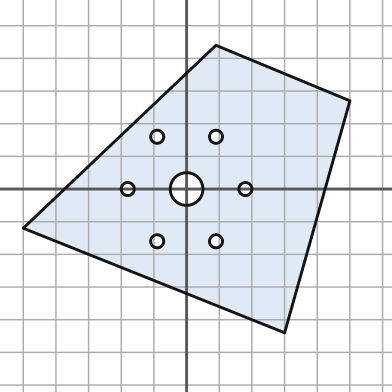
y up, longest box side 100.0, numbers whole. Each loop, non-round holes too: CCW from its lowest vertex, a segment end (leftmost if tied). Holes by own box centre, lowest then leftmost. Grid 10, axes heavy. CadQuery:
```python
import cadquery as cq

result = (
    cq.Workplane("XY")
    .moveTo(30.0, -44.0)
    .lineTo(50.0, 27.0)
    .lineTo(9.0, 44.0)
    .lineTo(-50.0, -12.0)
    .close()
    .moveTo(-9.0, -16.0)
    .circle(2.0)
    .moveTo(9.0, -16.0)
    .circle(2.0)
    .moveTo(-18.0, 0.0)
    .circle(2.0)
    .moveTo(0.0, 0.0)
    .circle(5.0)
    .moveTo(18.0, 0.0)
    .circle(2.0)
    .moveTo(-9.0, 16.0)
    .circle(2.0)
    .moveTo(9.0, 16.0)
    .circle(2.0)
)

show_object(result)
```